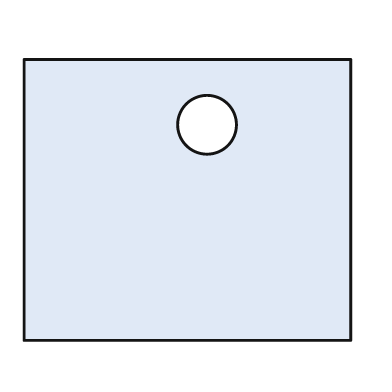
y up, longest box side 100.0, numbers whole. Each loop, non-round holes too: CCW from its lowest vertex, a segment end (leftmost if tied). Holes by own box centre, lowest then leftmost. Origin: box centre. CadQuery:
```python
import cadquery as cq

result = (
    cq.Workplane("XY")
    .moveTo(-50.0, -43.0)
    .lineTo(50.0, -43.0)
    .lineTo(50.0, 43.0)
    .lineTo(-50.0, 43.0)
    .close()
    .moveTo(6.0, 23.0)
    .circle(9.0)
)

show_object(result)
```